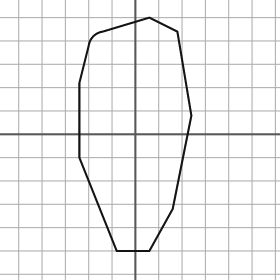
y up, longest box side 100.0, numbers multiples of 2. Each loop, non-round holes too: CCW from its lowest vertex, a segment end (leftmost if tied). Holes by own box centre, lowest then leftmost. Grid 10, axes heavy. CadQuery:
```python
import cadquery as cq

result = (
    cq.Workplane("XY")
    .moveTo(-8.0, -50.0)
    .lineTo(6.0, -50.0)
    .lineTo(16.0, -32.0)
    .lineTo(24.0, 8.0)
    .lineTo(18.0, 44.0)
    .lineTo(6.0, 50.0)
    .lineTo(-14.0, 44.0)
    .threePointArc((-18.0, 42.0), (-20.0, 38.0))
    .lineTo(-24.0, 22.0)
    .lineTo(-24.0, -10.0)
    .close()
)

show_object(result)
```